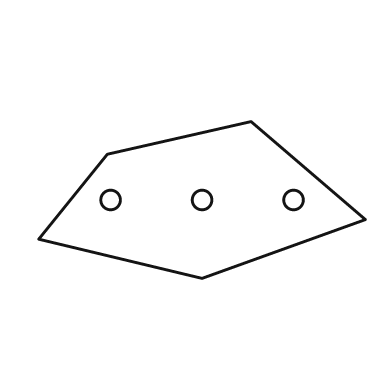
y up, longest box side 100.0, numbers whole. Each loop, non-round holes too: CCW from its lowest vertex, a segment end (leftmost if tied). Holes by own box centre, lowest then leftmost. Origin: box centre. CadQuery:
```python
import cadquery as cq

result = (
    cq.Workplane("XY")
    .moveTo(0.0, -24.0)
    .lineTo(50.0, -6.0)
    .lineTo(15.0, 24.0)
    .lineTo(-29.0, 14.0)
    .lineTo(-50.0, -12.0)
    .close()
    .moveTo(-28.0, 0.0)
    .circle(3.0)
    .moveTo(0.0, 0.0)
    .circle(3.0)
    .moveTo(28.0, 0.0)
    .circle(3.0)
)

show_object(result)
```